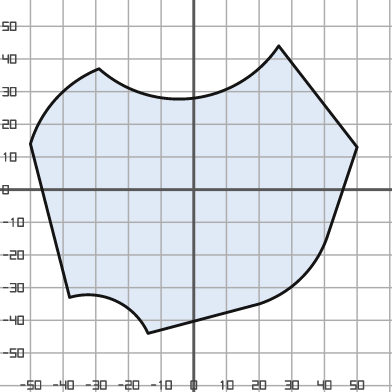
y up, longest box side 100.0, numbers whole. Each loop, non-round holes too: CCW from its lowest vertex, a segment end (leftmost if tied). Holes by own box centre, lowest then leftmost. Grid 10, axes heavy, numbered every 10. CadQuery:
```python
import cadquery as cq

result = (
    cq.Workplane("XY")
    .moveTo(-14.0, -44.0)
    .lineTo(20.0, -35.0)
    .threePointArc((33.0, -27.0), (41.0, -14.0))
    .lineTo(50.0, 13.0)
    .lineTo(26.0, 44.0)
    .threePointArc((0.0, 28.0), (-29.0, 37.0))
    .threePointArc((-42.0, 28.0), (-50.0, 14.0))
    .lineTo(-38.0, -33.0)
    .threePointArc((-24.0, -34.0), (-14.0, -44.0))
    .close()
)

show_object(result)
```